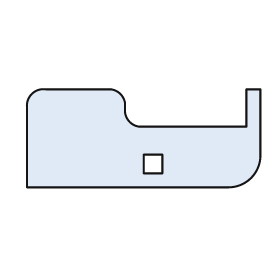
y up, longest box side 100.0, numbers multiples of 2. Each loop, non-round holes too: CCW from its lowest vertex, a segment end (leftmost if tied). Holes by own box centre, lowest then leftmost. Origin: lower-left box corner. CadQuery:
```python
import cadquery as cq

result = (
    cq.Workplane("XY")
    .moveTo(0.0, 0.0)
    .lineTo(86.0, 0.0)
    .threePointArc((96.0, 4.0), (100.0, 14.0))
    .lineTo(100.0, 42.0)
    .lineTo(94.0, 42.0)
    .lineTo(94.0, 26.0)
    .lineTo(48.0, 26.0)
    .threePointArc((44.0, 28.0), (42.0, 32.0))
    .lineTo(42.0, 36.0)
    .threePointArc((40.0, 40.0), (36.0, 42.0))
    .lineTo(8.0, 42.0)
    .threePointArc((2.0, 40.0), (0.0, 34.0))
    .close()
    .moveTo(50.0, 6.0)
    .lineTo(58.0, 6.0)
    .lineTo(58.0, 14.0)
    .lineTo(50.0, 14.0)
    .close()
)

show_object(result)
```